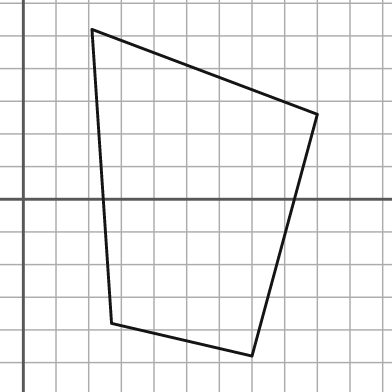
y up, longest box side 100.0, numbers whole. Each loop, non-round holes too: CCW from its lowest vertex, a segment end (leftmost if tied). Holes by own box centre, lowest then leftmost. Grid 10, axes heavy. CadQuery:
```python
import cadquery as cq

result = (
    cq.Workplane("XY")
    .moveTo(70.0, -48.0)
    .lineTo(90.0, 26.0)
    .lineTo(21.0, 52.0)
    .lineTo(27.0, -38.0)
    .close()
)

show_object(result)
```